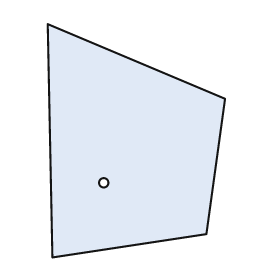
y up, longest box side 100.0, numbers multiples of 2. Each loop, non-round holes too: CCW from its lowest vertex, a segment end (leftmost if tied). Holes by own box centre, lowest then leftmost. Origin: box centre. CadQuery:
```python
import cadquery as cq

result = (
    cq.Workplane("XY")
    .moveTo(-36.0, -50.0)
    .lineTo(30.0, -40.0)
    .lineTo(38.0, 18.0)
    .lineTo(-38.0, 50.0)
    .close()
    .moveTo(-14.0, -18.0)
    .circle(2.0)
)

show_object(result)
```